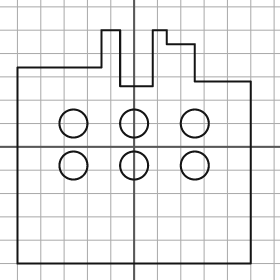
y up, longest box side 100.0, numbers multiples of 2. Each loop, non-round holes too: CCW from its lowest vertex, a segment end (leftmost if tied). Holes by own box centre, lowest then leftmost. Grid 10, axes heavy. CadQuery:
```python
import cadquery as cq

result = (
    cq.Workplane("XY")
    .moveTo(-50.0, -50.0)
    .lineTo(50.0, -50.0)
    .lineTo(50.0, 28.0)
    .lineTo(26.0, 28.0)
    .lineTo(26.0, 44.0)
    .lineTo(14.0, 44.0)
    .lineTo(14.0, 50.0)
    .lineTo(8.0, 50.0)
    .lineTo(8.0, 26.0)
    .lineTo(-6.0, 26.0)
    .lineTo(-6.0, 50.0)
    .lineTo(-14.0, 50.0)
    .lineTo(-14.0, 34.0)
    .lineTo(-50.0, 34.0)
    .close()
    .moveTo(-26.0, -8.0)
    .circle(6.0)
    .moveTo(0.0, -8.0)
    .circle(6.0)
    .moveTo(26.0, -8.0)
    .circle(6.0)
    .moveTo(-26.0, 10.0)
    .circle(6.0)
    .moveTo(0.0, 10.0)
    .circle(6.0)
    .moveTo(26.0, 10.0)
    .circle(6.0)
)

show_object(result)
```